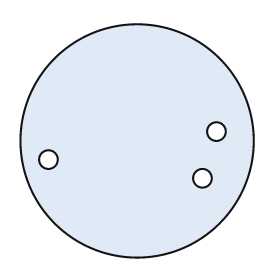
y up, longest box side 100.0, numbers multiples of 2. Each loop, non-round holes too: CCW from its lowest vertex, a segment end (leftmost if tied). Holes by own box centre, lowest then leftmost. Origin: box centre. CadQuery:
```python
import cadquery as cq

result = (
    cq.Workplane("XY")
    .moveTo(0.0, 0.0)
    .circle(50.0)
    .moveTo(28.0, -16.0)
    .circle(4.0)
    .moveTo(-38.0, -8.0)
    .circle(4.0)
    .moveTo(34.0, 4.0)
    .circle(4.0)
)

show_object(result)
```